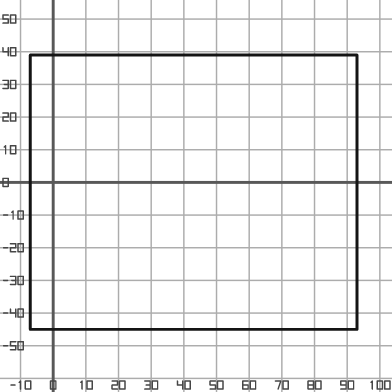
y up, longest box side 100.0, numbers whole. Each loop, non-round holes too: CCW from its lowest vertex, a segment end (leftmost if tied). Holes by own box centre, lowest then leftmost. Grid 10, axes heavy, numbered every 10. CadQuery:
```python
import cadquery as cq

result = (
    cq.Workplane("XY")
    .moveTo(-7.0, -45.0)
    .lineTo(93.0, -45.0)
    .lineTo(93.0, 39.0)
    .lineTo(-7.0, 39.0)
    .close()
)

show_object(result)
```